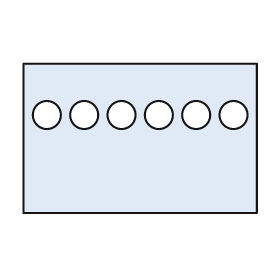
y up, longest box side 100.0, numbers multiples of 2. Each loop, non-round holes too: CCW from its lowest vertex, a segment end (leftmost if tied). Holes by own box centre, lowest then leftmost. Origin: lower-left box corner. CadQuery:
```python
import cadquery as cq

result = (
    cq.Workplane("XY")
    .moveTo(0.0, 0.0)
    .lineTo(100.0, 0.0)
    .lineTo(100.0, 64.0)
    .lineTo(0.0, 64.0)
    .close()
    .moveTo(10.0, 42.0)
    .circle(6.0)
    .moveTo(26.0, 42.0)
    .circle(6.0)
    .moveTo(42.0, 42.0)
    .circle(6.0)
    .moveTo(58.0, 42.0)
    .circle(6.0)
    .moveTo(74.0, 42.0)
    .circle(6.0)
    .moveTo(90.0, 42.0)
    .circle(6.0)
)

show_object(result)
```